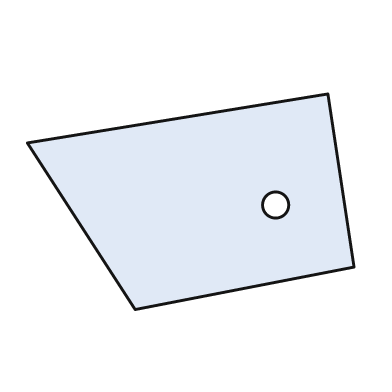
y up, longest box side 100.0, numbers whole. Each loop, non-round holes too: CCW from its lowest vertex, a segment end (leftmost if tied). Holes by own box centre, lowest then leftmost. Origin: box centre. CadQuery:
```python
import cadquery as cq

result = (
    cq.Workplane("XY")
    .moveTo(-17.0, -33.0)
    .lineTo(50.0, -20.0)
    .lineTo(42.0, 33.0)
    .lineTo(-50.0, 18.0)
    .close()
    .moveTo(26.0, -1.0)
    .circle(4.0)
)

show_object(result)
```